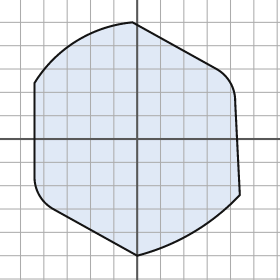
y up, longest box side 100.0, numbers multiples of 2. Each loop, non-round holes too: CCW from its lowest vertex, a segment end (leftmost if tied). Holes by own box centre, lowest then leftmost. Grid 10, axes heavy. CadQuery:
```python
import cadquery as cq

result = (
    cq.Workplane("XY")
    .moveTo(0.0, -50.0)
    .threePointArc((24.0, -40.0), (44.0, -24.0))
    .lineTo(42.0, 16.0)
    .threePointArc((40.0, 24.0), (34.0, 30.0))
    .lineTo(-2.0, 50.0)
    .threePointArc((-26.0, 42.0), (-44.0, 24.0))
    .lineTo(-44.0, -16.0)
    .threePointArc((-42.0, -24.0), (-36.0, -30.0))
    .close()
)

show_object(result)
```